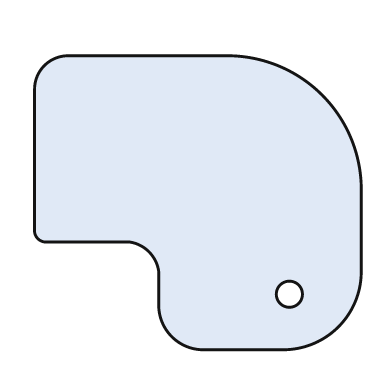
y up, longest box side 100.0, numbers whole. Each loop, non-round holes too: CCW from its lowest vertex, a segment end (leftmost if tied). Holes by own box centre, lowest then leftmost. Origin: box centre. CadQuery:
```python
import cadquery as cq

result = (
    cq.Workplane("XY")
    .moveTo(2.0, -45.0)
    .lineTo(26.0, -45.0)
    .threePointArc((43.0, -38.0), (50.0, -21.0))
    .lineTo(50.0, 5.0)
    .threePointArc((38.0, 33.0), (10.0, 45.0))
    .lineTo(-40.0, 45.0)
    .threePointArc((-47.0, 42.0), (-50.0, 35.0))
    .lineTo(-50.0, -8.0)
    .threePointArc((-49.0, -11.0), (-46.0, -12.0))
    .lineTo(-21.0, -12.0)
    .threePointArc((-15.0, -15.0), (-12.0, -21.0))
    .lineTo(-12.0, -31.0)
    .threePointArc((-8.0, -41.0), (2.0, -45.0))
    .close()
    .moveTo(28.0, -28.0)
    .circle(4.0)
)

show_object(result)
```